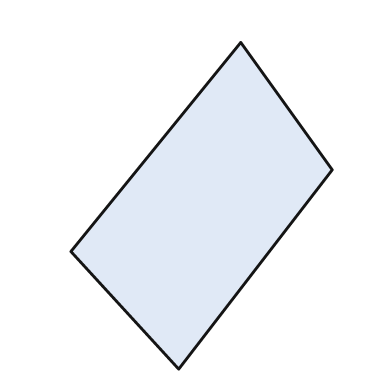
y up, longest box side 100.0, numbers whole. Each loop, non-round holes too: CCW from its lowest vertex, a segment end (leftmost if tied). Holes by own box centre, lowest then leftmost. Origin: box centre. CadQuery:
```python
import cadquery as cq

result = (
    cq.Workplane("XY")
    .moveTo(-7.0, -50.0)
    .lineTo(40.0, 11.0)
    .lineTo(12.0, 50.0)
    .lineTo(-40.0, -14.0)
    .close()
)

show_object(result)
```